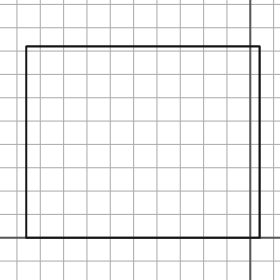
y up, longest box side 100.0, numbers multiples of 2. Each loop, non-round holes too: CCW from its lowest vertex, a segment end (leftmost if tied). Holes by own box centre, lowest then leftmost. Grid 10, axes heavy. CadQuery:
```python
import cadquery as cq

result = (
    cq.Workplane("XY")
    .moveTo(-96.0, 0.0)
    .lineTo(4.0, 0.0)
    .lineTo(4.0, 82.0)
    .lineTo(-96.0, 82.0)
    .close()
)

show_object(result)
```